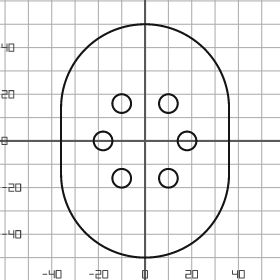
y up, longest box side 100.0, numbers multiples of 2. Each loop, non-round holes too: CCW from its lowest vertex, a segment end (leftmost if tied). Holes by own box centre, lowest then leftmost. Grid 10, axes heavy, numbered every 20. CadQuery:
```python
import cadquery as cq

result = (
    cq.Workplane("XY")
    .moveTo(-36.0, -14.0)
    .threePointArc((0.0, -50.0), (36.0, -14.0))
    .lineTo(36.0, 14.0)
    .threePointArc((0.0, 50.0), (-36.0, 14.0))
    .close()
    .moveTo(-10.0, -16.0)
    .circle(4.0)
    .moveTo(10.0, -16.0)
    .circle(4.0)
    .moveTo(-18.0, 0.0)
    .circle(4.0)
    .moveTo(18.0, 0.0)
    .circle(4.0)
    .moveTo(-10.0, 16.0)
    .circle(4.0)
    .moveTo(10.0, 16.0)
    .circle(4.0)
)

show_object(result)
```